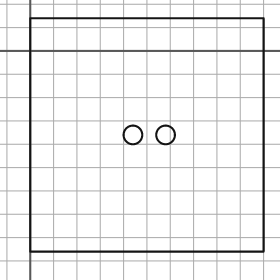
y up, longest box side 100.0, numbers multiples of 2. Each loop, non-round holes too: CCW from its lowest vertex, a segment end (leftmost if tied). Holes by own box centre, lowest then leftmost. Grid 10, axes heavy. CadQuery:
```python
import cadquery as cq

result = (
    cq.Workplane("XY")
    .moveTo(0.0, -86.0)
    .lineTo(100.0, -86.0)
    .lineTo(100.0, 14.0)
    .lineTo(0.0, 14.0)
    .close()
    .moveTo(44.0, -36.0)
    .circle(4.0)
    .moveTo(58.0, -36.0)
    .circle(4.0)
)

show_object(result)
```